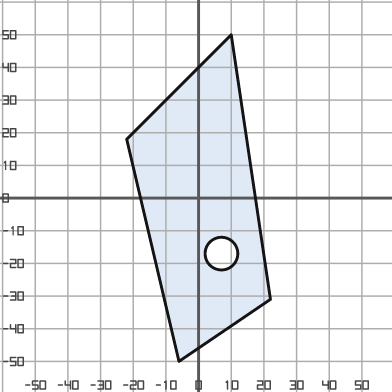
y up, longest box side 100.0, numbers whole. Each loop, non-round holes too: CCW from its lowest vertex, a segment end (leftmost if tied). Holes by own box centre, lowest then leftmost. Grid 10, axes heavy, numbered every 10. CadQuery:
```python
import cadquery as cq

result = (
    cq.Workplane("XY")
    .moveTo(-6.0, -50.0)
    .lineTo(22.0, -31.0)
    .lineTo(10.0, 50.0)
    .lineTo(-22.0, 18.0)
    .close()
    .moveTo(7.0, -17.0)
    .circle(5.0)
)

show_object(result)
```